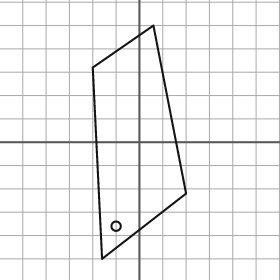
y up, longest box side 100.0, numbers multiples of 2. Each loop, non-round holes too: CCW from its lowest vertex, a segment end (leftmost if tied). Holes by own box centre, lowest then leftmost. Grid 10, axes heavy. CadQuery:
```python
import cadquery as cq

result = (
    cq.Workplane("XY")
    .moveTo(-16.0, -50.0)
    .lineTo(20.0, -22.0)
    .lineTo(6.0, 50.0)
    .lineTo(-20.0, 32.0)
    .close()
    .moveTo(-10.0, -36.0)
    .circle(2.0)
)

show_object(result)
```